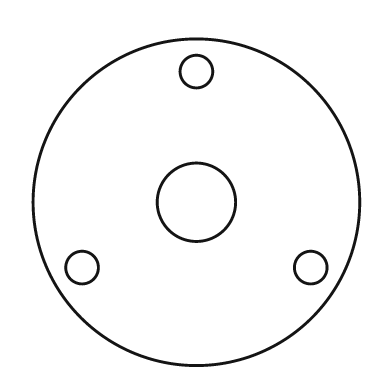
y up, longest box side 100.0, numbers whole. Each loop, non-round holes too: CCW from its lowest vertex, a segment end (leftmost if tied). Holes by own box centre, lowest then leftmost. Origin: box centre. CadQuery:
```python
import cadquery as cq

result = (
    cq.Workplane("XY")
    .moveTo(0.0, 0.0)
    .circle(50.0)
    .moveTo(-35.0, -20.0)
    .circle(5.0)
    .moveTo(35.0, -20.0)
    .circle(5.0)
    .moveTo(0.0, 0.0)
    .circle(12.0)
    .moveTo(0.0, 40.0)
    .circle(5.0)
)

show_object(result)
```